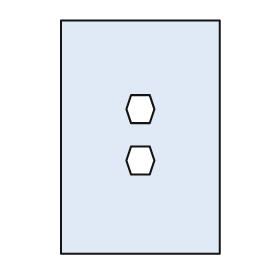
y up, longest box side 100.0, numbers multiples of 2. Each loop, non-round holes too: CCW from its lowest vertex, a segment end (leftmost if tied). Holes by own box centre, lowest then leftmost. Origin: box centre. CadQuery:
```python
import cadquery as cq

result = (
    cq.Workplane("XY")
    .moveTo(-34.0, -50.0)
    .lineTo(34.0, -50.0)
    .lineTo(34.0, 50.0)
    .lineTo(-34.0, 50.0)
    .close()
    .moveTo(-4.0, -16.0)
    .lineTo(4.0, -16.0)
    .lineTo(6.0, -10.0)
    .lineTo(4.0, -4.0)
    .lineTo(-4.0, -4.0)
    .lineTo(-6.0, -10.0)
    .close()
    .moveTo(-4.0, 6.0)
    .lineTo(4.0, 6.0)
    .lineTo(6.0, 12.0)
    .lineTo(4.0, 18.0)
    .lineTo(-4.0, 18.0)
    .lineTo(-6.0, 12.0)
    .close()
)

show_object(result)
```